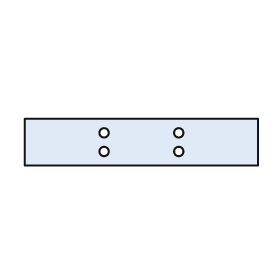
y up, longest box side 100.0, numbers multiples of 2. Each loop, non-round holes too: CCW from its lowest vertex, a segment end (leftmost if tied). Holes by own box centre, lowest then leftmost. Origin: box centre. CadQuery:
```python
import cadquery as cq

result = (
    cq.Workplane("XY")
    .moveTo(-50.0, -10.0)
    .lineTo(50.0, -10.0)
    .lineTo(50.0, 10.0)
    .lineTo(-50.0, 10.0)
    .close()
    .moveTo(-16.0, -4.0)
    .circle(2.0)
    .moveTo(16.0, -4.0)
    .circle(2.0)
    .moveTo(-16.0, 4.0)
    .circle(2.0)
    .moveTo(16.0, 4.0)
    .circle(2.0)
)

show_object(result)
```